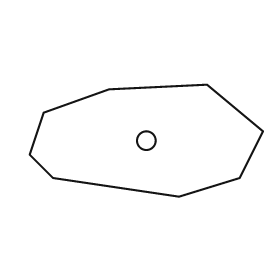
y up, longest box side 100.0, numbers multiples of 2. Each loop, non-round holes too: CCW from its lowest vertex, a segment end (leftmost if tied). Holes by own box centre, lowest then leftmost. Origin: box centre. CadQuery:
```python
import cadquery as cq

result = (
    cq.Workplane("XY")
    .moveTo(14.0, -24.0)
    .lineTo(40.0, -16.0)
    .lineTo(50.0, 4.0)
    .lineTo(26.0, 24.0)
    .lineTo(-16.0, 22.0)
    .lineTo(-44.0, 12.0)
    .lineTo(-50.0, -6.0)
    .lineTo(-40.0, -16.0)
    .close()
    .moveTo(0.0, 0.0)
    .circle(4.0)
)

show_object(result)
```